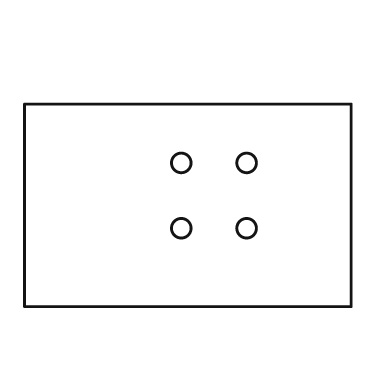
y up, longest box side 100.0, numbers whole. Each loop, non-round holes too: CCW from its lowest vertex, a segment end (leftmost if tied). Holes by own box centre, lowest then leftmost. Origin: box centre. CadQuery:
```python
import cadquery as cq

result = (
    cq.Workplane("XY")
    .moveTo(-50.0, -31.0)
    .lineTo(50.0, -31.0)
    .lineTo(50.0, 31.0)
    .lineTo(-50.0, 31.0)
    .close()
    .moveTo(-2.0, -7.0)
    .circle(3.0)
    .moveTo(18.0, -7.0)
    .circle(3.0)
    .moveTo(-2.0, 13.0)
    .circle(3.0)
    .moveTo(18.0, 13.0)
    .circle(3.0)
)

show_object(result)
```